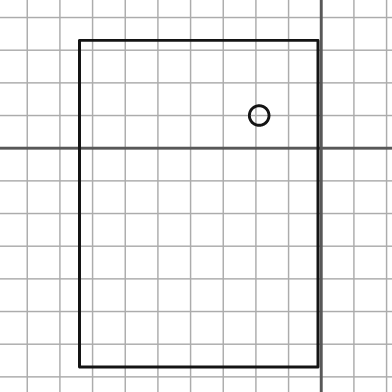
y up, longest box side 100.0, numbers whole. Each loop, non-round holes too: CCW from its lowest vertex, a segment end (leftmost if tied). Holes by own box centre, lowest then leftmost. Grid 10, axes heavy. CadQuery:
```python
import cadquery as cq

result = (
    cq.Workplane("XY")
    .moveTo(-74.0, -67.0)
    .lineTo(-1.0, -67.0)
    .lineTo(-1.0, 33.0)
    .lineTo(-74.0, 33.0)
    .close()
    .moveTo(-19.0, 10.0)
    .circle(3.0)
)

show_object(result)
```